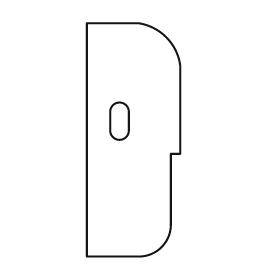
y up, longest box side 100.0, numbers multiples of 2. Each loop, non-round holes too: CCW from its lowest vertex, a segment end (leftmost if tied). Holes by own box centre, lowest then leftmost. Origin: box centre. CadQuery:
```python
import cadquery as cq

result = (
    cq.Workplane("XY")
    .moveTo(-20.0, -50.0)
    .lineTo(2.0, -50.0)
    .threePointArc((12.0, -46.0), (16.0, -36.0))
    .lineTo(16.0, -6.0)
    .lineTo(20.0, -6.0)
    .lineTo(20.0, 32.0)
    .threePointArc((14.0, 44.0), (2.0, 50.0))
    .lineTo(-20.0, 50.0)
    .close()
    .moveTo(-10.0, 4.0)
    .threePointArc((-6.0, 0.0), (-2.0, 4.0))
    .lineTo(-2.0, 12.0)
    .threePointArc((-6.0, 16.0), (-10.0, 12.0))
    .close()
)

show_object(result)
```